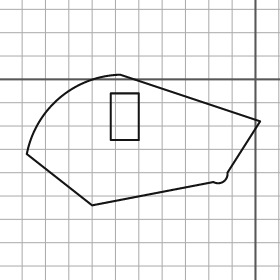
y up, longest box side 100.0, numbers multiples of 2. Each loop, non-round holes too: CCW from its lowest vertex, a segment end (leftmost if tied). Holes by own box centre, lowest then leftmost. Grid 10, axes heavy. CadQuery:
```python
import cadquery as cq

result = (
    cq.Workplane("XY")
    .moveTo(-70.0, -54.0)
    .lineTo(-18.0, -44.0)
    .threePointArc((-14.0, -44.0), (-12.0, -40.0))
    .lineTo(2.0, -18.0)
    .lineTo(-58.0, 2.0)
    .threePointArc((-84.0, -8.0), (-98.0, -32.0))
    .close()
    .moveTo(-62.0, -26.0)
    .lineTo(-50.0, -26.0)
    .lineTo(-50.0, -6.0)
    .lineTo(-62.0, -6.0)
    .close()
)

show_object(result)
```